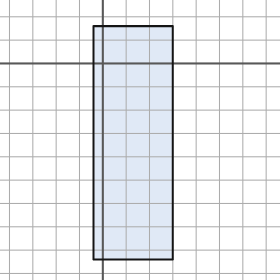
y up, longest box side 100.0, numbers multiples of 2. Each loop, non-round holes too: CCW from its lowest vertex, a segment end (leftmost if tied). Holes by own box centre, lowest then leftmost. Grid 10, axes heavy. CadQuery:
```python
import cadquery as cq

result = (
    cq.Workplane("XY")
    .moveTo(-4.0, -84.0)
    .lineTo(30.0, -84.0)
    .lineTo(30.0, 16.0)
    .lineTo(-4.0, 16.0)
    .close()
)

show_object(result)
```